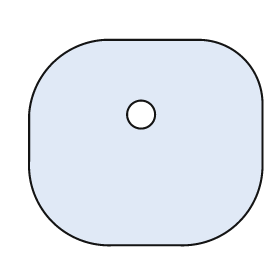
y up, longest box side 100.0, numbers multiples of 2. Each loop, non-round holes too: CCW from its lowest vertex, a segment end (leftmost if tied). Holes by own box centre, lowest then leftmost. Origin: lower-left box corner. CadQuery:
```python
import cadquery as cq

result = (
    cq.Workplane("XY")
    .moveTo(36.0, 0.0)
    .lineTo(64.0, 0.0)
    .threePointArc((90.0, 10.0), (100.0, 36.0))
    .lineTo(100.0, 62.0)
    .threePointArc((92.0, 80.0), (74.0, 88.0))
    .lineTo(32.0, 88.0)
    .threePointArc((10.0, 78.0), (0.0, 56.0))
    .lineTo(0.0, 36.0)
    .threePointArc((10.0, 10.0), (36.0, 0.0))
    .close()
    .moveTo(48.0, 56.0)
    .circle(6.0)
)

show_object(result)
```